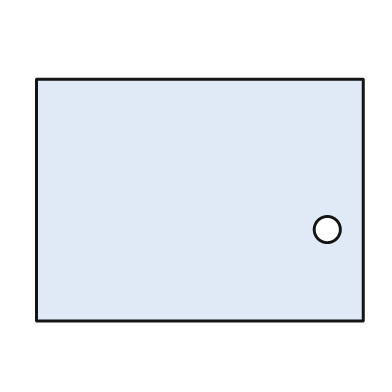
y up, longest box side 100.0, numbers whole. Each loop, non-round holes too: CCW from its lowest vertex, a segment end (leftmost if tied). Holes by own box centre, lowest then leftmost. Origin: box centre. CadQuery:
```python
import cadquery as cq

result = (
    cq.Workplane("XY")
    .moveTo(-50.0, -37.0)
    .lineTo(50.0, -37.0)
    .lineTo(50.0, 37.0)
    .lineTo(-50.0, 37.0)
    .close()
    .moveTo(39.0, -9.0)
    .circle(4.0)
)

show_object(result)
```